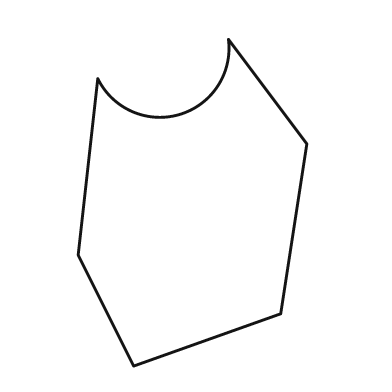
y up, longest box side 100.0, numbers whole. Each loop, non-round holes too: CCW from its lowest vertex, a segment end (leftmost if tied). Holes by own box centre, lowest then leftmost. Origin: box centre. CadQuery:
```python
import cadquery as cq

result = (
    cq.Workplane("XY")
    .moveTo(-18.0, -50.0)
    .lineTo(27.0, -34.0)
    .lineTo(35.0, 18.0)
    .lineTo(11.0, 50.0)
    .threePointArc((-4.0, 27.0), (-29.0, 38.0))
    .lineTo(-35.0, -16.0)
    .close()
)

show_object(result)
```